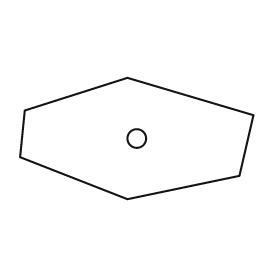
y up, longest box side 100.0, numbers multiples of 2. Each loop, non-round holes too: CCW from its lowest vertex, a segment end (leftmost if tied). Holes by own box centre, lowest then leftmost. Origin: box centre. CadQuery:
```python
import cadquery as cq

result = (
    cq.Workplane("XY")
    .moveTo(-4.0, -26.0)
    .lineTo(44.0, -16.0)
    .lineTo(50.0, 10.0)
    .lineTo(-4.0, 26.0)
    .lineTo(-48.0, 12.0)
    .lineTo(-50.0, -8.0)
    .close()
    .moveTo(0.0, 0.0)
    .circle(4.0)
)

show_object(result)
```